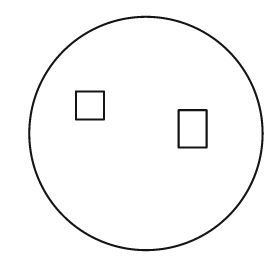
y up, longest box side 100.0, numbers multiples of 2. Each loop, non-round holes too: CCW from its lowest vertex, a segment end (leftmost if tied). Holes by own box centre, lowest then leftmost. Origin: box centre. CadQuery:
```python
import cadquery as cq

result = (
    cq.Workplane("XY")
    .moveTo(0.0, 0.0)
    .circle(50.0)
    .moveTo(14.0, -6.0)
    .lineTo(26.0, -6.0)
    .lineTo(26.0, 10.0)
    .lineTo(14.0, 10.0)
    .close()
    .moveTo(-30.0, 6.0)
    .lineTo(-18.0, 6.0)
    .lineTo(-18.0, 18.0)
    .lineTo(-30.0, 18.0)
    .close()
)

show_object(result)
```